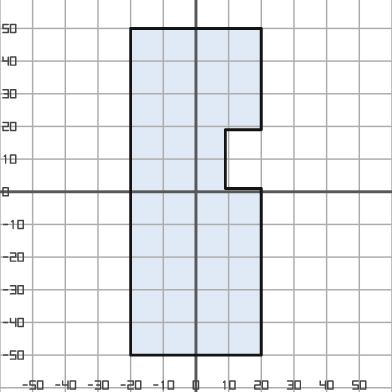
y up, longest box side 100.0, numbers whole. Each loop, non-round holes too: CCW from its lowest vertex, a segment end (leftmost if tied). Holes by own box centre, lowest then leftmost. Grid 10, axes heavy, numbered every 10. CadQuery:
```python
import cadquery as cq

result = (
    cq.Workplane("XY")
    .moveTo(-20.0, -50.0)
    .lineTo(20.0, -50.0)
    .lineTo(20.0, 1.0)
    .lineTo(9.0, 1.0)
    .lineTo(9.0, 19.0)
    .lineTo(20.0, 19.0)
    .lineTo(20.0, 50.0)
    .lineTo(-20.0, 50.0)
    .close()
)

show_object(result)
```